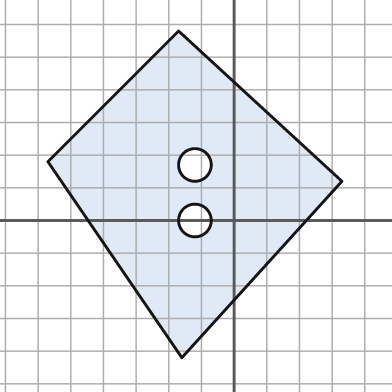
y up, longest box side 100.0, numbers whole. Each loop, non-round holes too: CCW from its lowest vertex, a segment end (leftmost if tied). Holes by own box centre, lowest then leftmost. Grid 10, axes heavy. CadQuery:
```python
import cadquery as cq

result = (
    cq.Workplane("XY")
    .moveTo(-16.0, -42.0)
    .lineTo(33.0, 12.0)
    .lineTo(-17.0, 58.0)
    .lineTo(-57.0, 18.0)
    .close()
    .moveTo(-12.0, 0.0)
    .circle(5.0)
    .moveTo(-12.0, 17.0)
    .circle(5.0)
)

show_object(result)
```